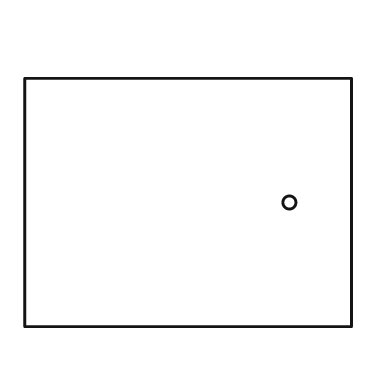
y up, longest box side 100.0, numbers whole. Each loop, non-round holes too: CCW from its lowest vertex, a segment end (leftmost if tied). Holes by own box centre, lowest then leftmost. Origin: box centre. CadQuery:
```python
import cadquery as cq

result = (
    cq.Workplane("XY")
    .moveTo(-50.0, -38.0)
    .lineTo(50.0, -38.0)
    .lineTo(50.0, 38.0)
    .lineTo(-50.0, 38.0)
    .close()
    .moveTo(31.0, 0.0)
    .circle(2.0)
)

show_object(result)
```